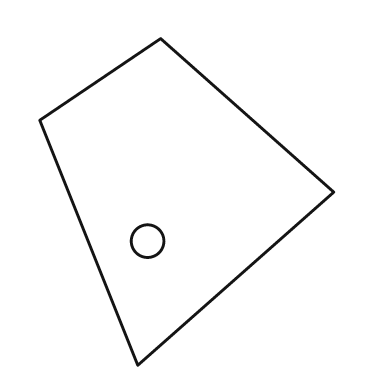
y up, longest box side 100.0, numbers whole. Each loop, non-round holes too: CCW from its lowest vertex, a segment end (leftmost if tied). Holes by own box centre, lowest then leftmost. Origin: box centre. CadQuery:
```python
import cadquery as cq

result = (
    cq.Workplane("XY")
    .moveTo(-15.0, -50.0)
    .lineTo(45.0, 3.0)
    .lineTo(-8.0, 50.0)
    .lineTo(-45.0, 25.0)
    .close()
    .moveTo(-12.0, -12.0)
    .circle(5.0)
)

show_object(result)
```